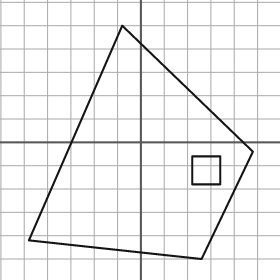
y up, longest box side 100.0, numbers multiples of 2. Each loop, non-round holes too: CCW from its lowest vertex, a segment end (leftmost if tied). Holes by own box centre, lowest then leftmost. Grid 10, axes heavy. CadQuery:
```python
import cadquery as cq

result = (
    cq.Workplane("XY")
    .moveTo(26.0, -50.0)
    .lineTo(48.0, -4.0)
    .lineTo(-8.0, 50.0)
    .lineTo(-48.0, -42.0)
    .close()
    .moveTo(22.0, -18.0)
    .lineTo(34.0, -18.0)
    .lineTo(34.0, -6.0)
    .lineTo(22.0, -6.0)
    .close()
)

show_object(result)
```